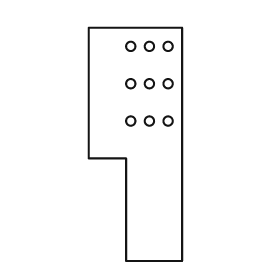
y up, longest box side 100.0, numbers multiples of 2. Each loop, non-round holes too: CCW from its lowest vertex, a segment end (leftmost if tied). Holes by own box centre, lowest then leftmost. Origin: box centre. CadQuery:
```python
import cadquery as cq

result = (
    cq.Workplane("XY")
    .moveTo(-4.0, -50.0)
    .lineTo(20.0, -50.0)
    .lineTo(20.0, 50.0)
    .lineTo(-20.0, 50.0)
    .lineTo(-20.0, -6.0)
    .lineTo(-4.0, -6.0)
    .close()
    .moveTo(-2.0, 10.0)
    .circle(2.0)
    .moveTo(6.0, 10.0)
    .circle(2.0)
    .moveTo(14.0, 10.0)
    .circle(2.0)
    .moveTo(-2.0, 26.0)
    .circle(2.0)
    .moveTo(6.0, 26.0)
    .circle(2.0)
    .moveTo(14.0, 26.0)
    .circle(2.0)
    .moveTo(-2.0, 42.0)
    .circle(2.0)
    .moveTo(6.0, 42.0)
    .circle(2.0)
    .moveTo(14.0, 42.0)
    .circle(2.0)
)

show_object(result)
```